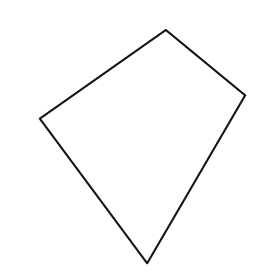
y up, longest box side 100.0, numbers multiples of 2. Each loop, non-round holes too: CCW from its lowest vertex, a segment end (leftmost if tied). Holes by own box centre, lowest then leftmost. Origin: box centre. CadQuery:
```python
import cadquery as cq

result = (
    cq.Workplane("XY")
    .moveTo(2.0, -50.0)
    .lineTo(44.0, 22.0)
    .lineTo(10.0, 50.0)
    .lineTo(-44.0, 12.0)
    .close()
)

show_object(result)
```